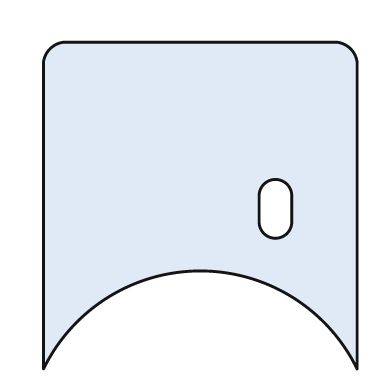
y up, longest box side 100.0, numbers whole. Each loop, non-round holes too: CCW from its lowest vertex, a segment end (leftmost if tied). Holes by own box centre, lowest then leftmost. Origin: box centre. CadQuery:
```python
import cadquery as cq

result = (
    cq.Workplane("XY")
    .moveTo(-48.0, -50.0)
    .threePointArc((0.0, -20.0), (48.0, -50.0))
    .lineTo(48.0, 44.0)
    .threePointArc((46.0, 48.0), (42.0, 50.0))
    .lineTo(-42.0, 50.0)
    .threePointArc((-46.0, 48.0), (-48.0, 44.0))
    .close()
    .moveTo(18.0, -5.0)
    .threePointArc((23.0, -10.0), (28.0, -5.0))
    .lineTo(28.0, 3.0)
    .threePointArc((23.0, 8.0), (18.0, 3.0))
    .close()
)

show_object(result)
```